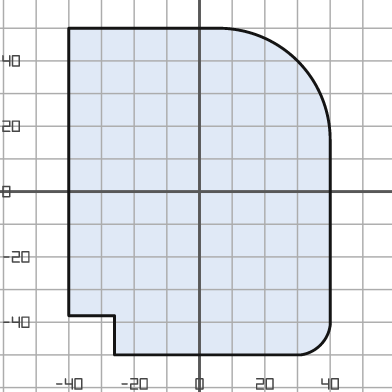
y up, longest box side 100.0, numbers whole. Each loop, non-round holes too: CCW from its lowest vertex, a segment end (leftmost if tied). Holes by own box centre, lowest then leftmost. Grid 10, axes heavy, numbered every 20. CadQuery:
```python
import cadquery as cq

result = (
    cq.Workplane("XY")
    .moveTo(-26.0, -50.0)
    .lineTo(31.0, -50.0)
    .threePointArc((37.0, -47.0), (40.0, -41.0))
    .lineTo(40.0, 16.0)
    .threePointArc((30.0, 40.0), (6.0, 50.0))
    .lineTo(-40.0, 50.0)
    .lineTo(-40.0, -38.0)
    .lineTo(-26.0, -38.0)
    .close()
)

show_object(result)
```